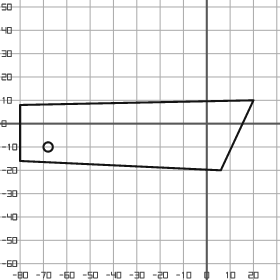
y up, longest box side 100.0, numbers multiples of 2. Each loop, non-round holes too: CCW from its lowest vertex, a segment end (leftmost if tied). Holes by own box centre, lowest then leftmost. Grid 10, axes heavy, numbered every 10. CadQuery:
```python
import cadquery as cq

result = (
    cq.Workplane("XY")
    .moveTo(6.0, -20.0)
    .lineTo(20.0, 10.0)
    .lineTo(-80.0, 8.0)
    .lineTo(-80.0, -16.0)
    .close()
    .moveTo(-68.0, -10.0)
    .circle(2.0)
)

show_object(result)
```